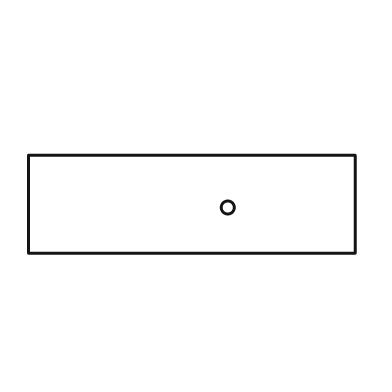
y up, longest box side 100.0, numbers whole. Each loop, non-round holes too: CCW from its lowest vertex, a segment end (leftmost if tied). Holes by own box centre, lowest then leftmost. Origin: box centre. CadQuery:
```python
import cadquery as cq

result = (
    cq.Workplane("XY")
    .moveTo(-50.0, -15.0)
    .lineTo(50.0, -15.0)
    .lineTo(50.0, 15.0)
    .lineTo(-50.0, 15.0)
    .close()
    .moveTo(11.0, -1.0)
    .circle(2.0)
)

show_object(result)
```